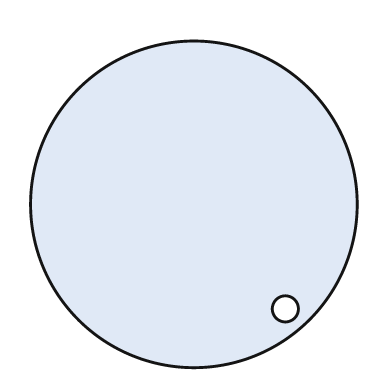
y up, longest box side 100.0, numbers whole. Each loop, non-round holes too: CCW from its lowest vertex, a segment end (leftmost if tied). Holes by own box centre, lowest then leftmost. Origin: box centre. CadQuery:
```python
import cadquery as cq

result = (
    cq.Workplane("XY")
    .moveTo(0.0, 0.0)
    .circle(50.0)
    .moveTo(28.0, -32.0)
    .circle(4.0)
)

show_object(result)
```